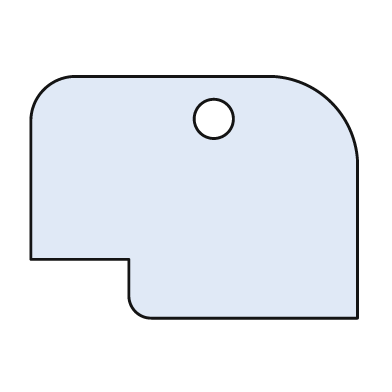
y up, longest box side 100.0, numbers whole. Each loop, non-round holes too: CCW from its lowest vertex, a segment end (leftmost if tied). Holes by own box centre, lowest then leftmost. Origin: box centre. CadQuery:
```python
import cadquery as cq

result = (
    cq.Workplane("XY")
    .moveTo(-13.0, -37.0)
    .lineTo(50.0, -37.0)
    .lineTo(50.0, 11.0)
    .threePointArc((42.0, 29.0), (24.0, 37.0))
    .lineTo(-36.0, 37.0)
    .threePointArc((-46.0, 33.0), (-50.0, 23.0))
    .lineTo(-50.0, -19.0)
    .lineTo(-20.0, -19.0)
    .lineTo(-20.0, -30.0)
    .threePointArc((-18.0, -35.0), (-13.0, -37.0))
    .close()
    .moveTo(6.0, 24.0)
    .circle(6.0)
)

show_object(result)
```